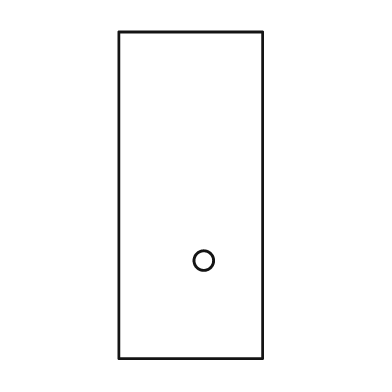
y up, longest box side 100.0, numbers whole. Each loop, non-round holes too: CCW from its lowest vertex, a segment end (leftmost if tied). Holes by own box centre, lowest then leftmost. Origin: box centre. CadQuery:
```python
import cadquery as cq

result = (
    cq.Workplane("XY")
    .moveTo(-22.0, -50.0)
    .lineTo(22.0, -50.0)
    .lineTo(22.0, 50.0)
    .lineTo(-22.0, 50.0)
    .close()
    .moveTo(4.0, -20.0)
    .circle(3.0)
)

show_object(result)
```